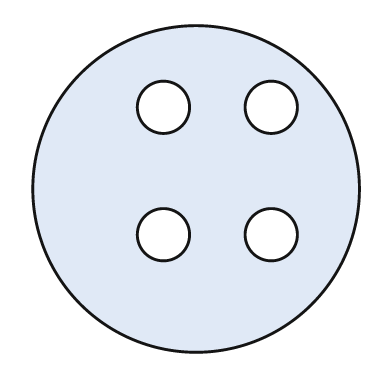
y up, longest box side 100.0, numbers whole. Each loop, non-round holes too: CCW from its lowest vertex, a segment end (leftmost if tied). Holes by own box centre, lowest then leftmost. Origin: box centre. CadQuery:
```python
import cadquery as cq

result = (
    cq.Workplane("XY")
    .moveTo(0.0, 0.0)
    .circle(50.0)
    .moveTo(-10.0, -14.0)
    .circle(8.0)
    .moveTo(23.0, -14.0)
    .circle(8.0)
    .moveTo(-10.0, 25.0)
    .circle(8.0)
    .moveTo(23.0, 25.0)
    .circle(8.0)
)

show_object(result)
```